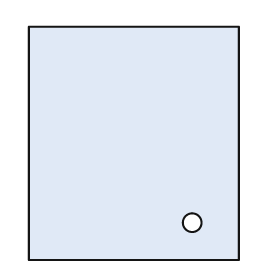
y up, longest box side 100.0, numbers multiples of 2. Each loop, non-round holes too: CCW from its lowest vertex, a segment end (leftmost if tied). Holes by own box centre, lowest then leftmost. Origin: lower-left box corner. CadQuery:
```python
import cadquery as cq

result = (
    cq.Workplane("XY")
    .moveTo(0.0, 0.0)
    .lineTo(90.0, 0.0)
    .lineTo(90.0, 100.0)
    .lineTo(0.0, 100.0)
    .close()
    .moveTo(70.0, 16.0)
    .circle(4.0)
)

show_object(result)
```